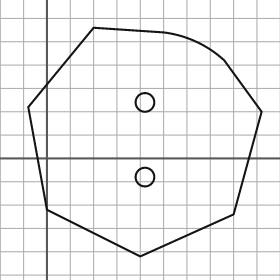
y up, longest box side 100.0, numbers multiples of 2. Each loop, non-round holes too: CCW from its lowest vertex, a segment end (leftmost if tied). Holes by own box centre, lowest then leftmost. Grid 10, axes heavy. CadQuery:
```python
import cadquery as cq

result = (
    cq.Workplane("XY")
    .moveTo(40.0, -42.0)
    .lineTo(80.0, -24.0)
    .lineTo(92.0, 20.0)
    .lineTo(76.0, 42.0)
    .threePointArc((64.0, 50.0), (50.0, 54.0))
    .lineTo(20.0, 56.0)
    .lineTo(-8.0, 22.0)
    .lineTo(0.0, -22.0)
    .close()
    .moveTo(42.0, -8.0)
    .circle(4.0)
    .moveTo(42.0, 24.0)
    .circle(4.0)
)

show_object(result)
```